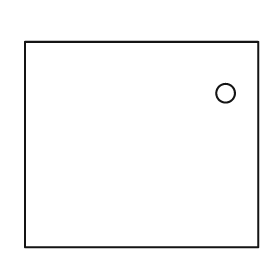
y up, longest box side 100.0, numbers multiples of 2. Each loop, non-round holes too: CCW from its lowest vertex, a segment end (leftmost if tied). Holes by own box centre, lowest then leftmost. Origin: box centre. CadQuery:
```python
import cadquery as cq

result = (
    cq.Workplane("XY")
    .moveTo(-50.0, -44.0)
    .lineTo(50.0, -44.0)
    .lineTo(50.0, 44.0)
    .lineTo(-50.0, 44.0)
    .close()
    .moveTo(36.0, 22.0)
    .circle(4.0)
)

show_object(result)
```